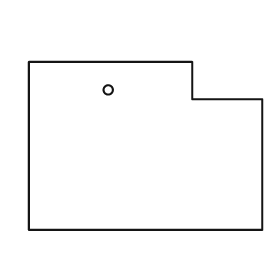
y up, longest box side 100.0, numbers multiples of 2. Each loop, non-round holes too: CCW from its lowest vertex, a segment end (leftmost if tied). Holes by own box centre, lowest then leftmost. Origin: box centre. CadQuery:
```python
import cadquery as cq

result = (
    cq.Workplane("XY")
    .moveTo(-50.0, -36.0)
    .lineTo(50.0, -36.0)
    .lineTo(50.0, 20.0)
    .lineTo(20.0, 20.0)
    .lineTo(20.0, 36.0)
    .lineTo(-50.0, 36.0)
    .close()
    .moveTo(-16.0, 24.0)
    .circle(2.0)
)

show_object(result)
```